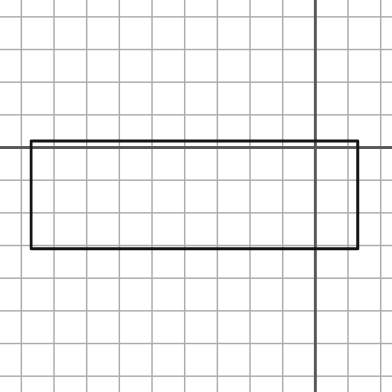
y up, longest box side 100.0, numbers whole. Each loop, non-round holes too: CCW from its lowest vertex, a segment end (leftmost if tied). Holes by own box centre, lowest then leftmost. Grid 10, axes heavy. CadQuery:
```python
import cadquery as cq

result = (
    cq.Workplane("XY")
    .moveTo(-87.0, -31.0)
    .lineTo(13.0, -31.0)
    .lineTo(13.0, 2.0)
    .lineTo(-87.0, 2.0)
    .close()
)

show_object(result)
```